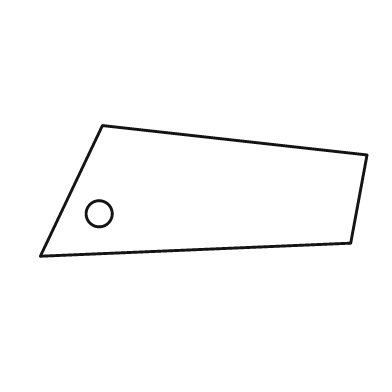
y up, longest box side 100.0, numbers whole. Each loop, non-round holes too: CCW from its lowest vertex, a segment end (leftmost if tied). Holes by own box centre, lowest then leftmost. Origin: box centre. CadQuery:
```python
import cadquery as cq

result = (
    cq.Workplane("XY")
    .moveTo(-50.0, -20.0)
    .lineTo(45.0, -16.0)
    .lineTo(50.0, 11.0)
    .lineTo(-31.0, 20.0)
    .close()
    .moveTo(-32.0, -7.0)
    .circle(4.0)
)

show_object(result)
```